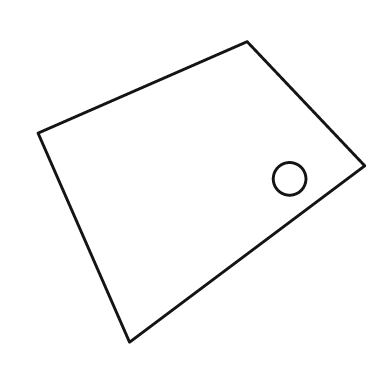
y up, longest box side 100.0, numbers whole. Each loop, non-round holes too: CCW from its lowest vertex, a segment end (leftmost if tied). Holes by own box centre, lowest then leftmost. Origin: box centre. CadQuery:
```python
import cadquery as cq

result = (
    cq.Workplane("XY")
    .moveTo(-22.0, -46.0)
    .lineTo(50.0, 8.0)
    .lineTo(14.0, 46.0)
    .lineTo(-50.0, 18.0)
    .close()
    .moveTo(27.0, 4.0)
    .circle(5.0)
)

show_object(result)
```